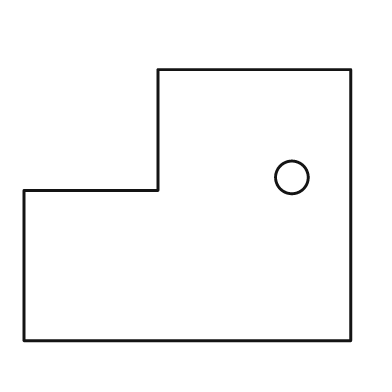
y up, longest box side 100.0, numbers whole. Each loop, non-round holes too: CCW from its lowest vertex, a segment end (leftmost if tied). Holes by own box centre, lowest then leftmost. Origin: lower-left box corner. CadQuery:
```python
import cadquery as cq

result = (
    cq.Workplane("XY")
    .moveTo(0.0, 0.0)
    .lineTo(100.0, 0.0)
    .lineTo(100.0, 83.0)
    .lineTo(41.0, 83.0)
    .lineTo(41.0, 46.0)
    .lineTo(0.0, 46.0)
    .close()
    .moveTo(82.0, 50.0)
    .circle(5.0)
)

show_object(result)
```